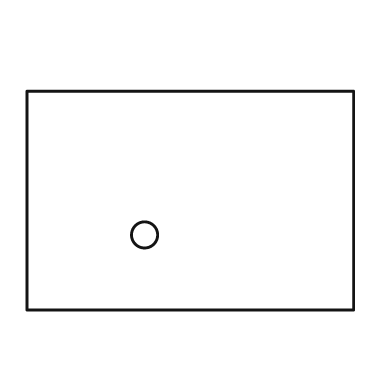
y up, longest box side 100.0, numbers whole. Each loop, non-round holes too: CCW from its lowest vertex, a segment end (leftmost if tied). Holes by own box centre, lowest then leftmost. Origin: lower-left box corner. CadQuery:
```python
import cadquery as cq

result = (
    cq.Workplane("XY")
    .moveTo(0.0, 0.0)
    .lineTo(100.0, 0.0)
    .lineTo(100.0, 67.0)
    .lineTo(0.0, 67.0)
    .close()
    .moveTo(36.0, 23.0)
    .circle(4.0)
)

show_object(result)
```